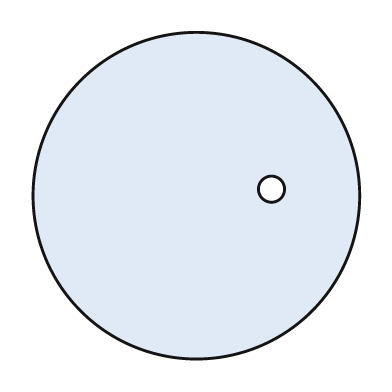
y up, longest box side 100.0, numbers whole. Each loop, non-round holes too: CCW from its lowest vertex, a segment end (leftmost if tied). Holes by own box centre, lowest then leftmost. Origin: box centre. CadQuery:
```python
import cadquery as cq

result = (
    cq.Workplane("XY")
    .moveTo(0.0, 0.0)
    .circle(50.0)
    .moveTo(23.0, 2.0)
    .circle(4.0)
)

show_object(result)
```